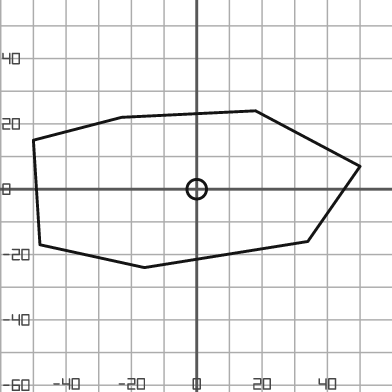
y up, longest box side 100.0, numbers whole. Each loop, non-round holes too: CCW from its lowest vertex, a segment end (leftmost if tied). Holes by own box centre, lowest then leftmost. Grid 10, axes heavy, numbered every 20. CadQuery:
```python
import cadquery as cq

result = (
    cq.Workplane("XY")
    .moveTo(-16.0, -24.0)
    .lineTo(34.0, -16.0)
    .lineTo(50.0, 7.0)
    .lineTo(18.0, 24.0)
    .lineTo(-23.0, 22.0)
    .lineTo(-50.0, 15.0)
    .lineTo(-48.0, -17.0)
    .close()
    .moveTo(0.0, 0.0)
    .circle(3.0)
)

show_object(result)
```